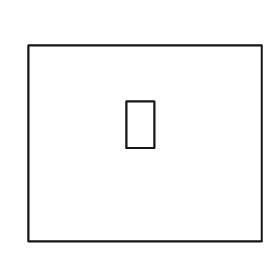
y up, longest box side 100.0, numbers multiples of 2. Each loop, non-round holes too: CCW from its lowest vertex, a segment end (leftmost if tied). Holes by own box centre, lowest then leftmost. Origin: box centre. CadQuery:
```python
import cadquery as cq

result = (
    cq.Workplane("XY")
    .moveTo(-50.0, -42.0)
    .lineTo(50.0, -42.0)
    .lineTo(50.0, 42.0)
    .lineTo(-50.0, 42.0)
    .close()
    .moveTo(-8.0, -2.0)
    .lineTo(4.0, -2.0)
    .lineTo(4.0, 18.0)
    .lineTo(-8.0, 18.0)
    .close()
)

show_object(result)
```